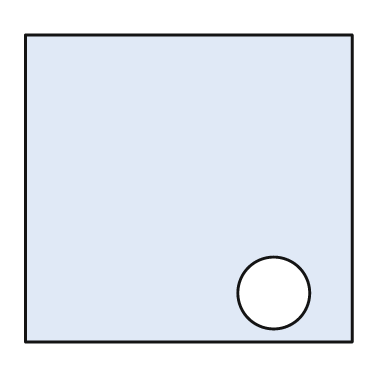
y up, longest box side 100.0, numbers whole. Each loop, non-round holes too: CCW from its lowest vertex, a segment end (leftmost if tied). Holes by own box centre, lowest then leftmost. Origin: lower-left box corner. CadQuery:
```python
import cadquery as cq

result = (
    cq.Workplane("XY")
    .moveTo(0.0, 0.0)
    .lineTo(100.0, 0.0)
    .lineTo(100.0, 94.0)
    .lineTo(0.0, 94.0)
    .close()
    .moveTo(76.0, 15.0)
    .circle(11.0)
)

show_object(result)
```